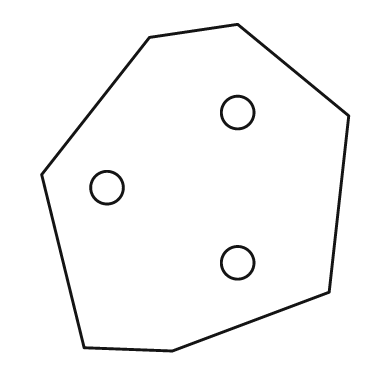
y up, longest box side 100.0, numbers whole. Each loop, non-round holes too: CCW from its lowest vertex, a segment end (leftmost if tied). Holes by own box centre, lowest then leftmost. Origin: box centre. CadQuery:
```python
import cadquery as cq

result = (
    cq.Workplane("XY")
    .moveTo(-7.0, -50.0)
    .lineTo(41.0, -32.0)
    .lineTo(47.0, 22.0)
    .lineTo(13.0, 50.0)
    .lineTo(-14.0, 46.0)
    .lineTo(-47.0, 4.0)
    .lineTo(-34.0, -49.0)
    .close()
    .moveTo(13.0, -23.0)
    .circle(5.0)
    .moveTo(-27.0, 0.0)
    .circle(5.0)
    .moveTo(13.0, 23.0)
    .circle(5.0)
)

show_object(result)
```